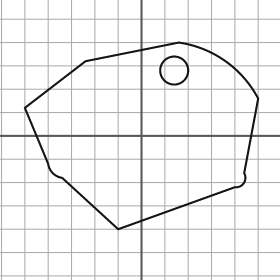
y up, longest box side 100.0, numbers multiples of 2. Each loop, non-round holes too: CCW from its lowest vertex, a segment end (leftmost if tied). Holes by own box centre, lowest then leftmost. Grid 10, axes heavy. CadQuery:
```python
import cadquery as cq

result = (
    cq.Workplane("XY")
    .moveTo(-10.0, -40.0)
    .lineTo(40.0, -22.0)
    .threePointArc((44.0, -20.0), (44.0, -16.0))
    .lineTo(50.0, 16.0)
    .threePointArc((36.0, 32.0), (16.0, 40.0))
    .lineTo(-24.0, 32.0)
    .lineTo(-50.0, 12.0)
    .lineTo(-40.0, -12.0)
    .threePointArc((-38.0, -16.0), (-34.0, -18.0))
    .close()
    .moveTo(14.0, 28.0)
    .circle(6.0)
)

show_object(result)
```